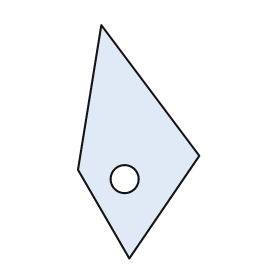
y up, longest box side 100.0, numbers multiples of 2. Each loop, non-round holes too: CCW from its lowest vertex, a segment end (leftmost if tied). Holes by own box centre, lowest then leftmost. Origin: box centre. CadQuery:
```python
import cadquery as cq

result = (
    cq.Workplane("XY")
    .moveTo(-4.0, -50.0)
    .lineTo(26.0, -6.0)
    .lineTo(-16.0, 50.0)
    .lineTo(-26.0, -12.0)
    .close()
    .moveTo(-6.0, -16.0)
    .circle(6.0)
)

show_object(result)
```